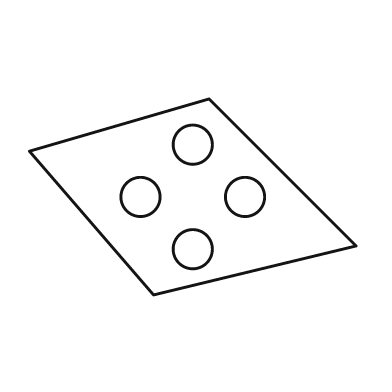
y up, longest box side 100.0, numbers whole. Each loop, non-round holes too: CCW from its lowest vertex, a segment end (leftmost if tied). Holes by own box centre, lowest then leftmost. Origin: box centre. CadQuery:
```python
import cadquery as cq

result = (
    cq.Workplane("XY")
    .moveTo(-12.0, -30.0)
    .lineTo(50.0, -15.0)
    .lineTo(5.0, 30.0)
    .lineTo(-50.0, 14.0)
    .close()
    .moveTo(0.0, -16.0)
    .circle(6.0)
    .moveTo(-16.0, 0.0)
    .circle(6.0)
    .moveTo(16.0, 0.0)
    .circle(6.0)
    .moveTo(0.0, 16.0)
    .circle(6.0)
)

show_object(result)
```